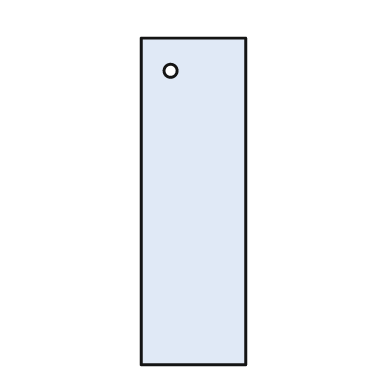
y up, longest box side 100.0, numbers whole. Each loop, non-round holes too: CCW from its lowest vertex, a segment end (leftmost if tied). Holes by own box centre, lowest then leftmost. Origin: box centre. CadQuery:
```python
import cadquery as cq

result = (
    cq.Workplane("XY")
    .moveTo(-16.0, -50.0)
    .lineTo(16.0, -50.0)
    .lineTo(16.0, 50.0)
    .lineTo(-16.0, 50.0)
    .close()
    .moveTo(-7.0, 40.0)
    .circle(2.0)
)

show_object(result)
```